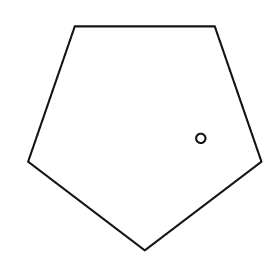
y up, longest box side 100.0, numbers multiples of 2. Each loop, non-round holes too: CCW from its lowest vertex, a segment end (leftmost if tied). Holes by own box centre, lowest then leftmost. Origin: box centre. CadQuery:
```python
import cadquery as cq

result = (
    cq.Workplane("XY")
    .moveTo(0.0, -48.0)
    .lineTo(50.0, -10.0)
    .lineTo(30.0, 48.0)
    .lineTo(-30.0, 48.0)
    .lineTo(-50.0, -10.0)
    .close()
    .moveTo(24.0, 0.0)
    .circle(2.0)
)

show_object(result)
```